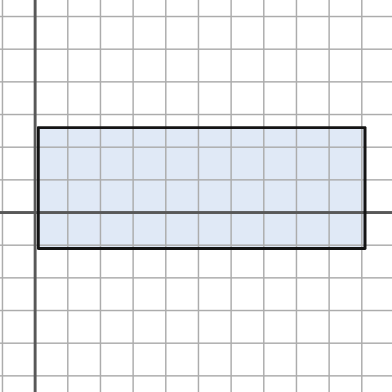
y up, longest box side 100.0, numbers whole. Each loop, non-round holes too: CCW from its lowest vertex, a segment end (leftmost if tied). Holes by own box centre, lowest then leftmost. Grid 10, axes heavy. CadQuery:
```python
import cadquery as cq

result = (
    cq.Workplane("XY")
    .moveTo(1.0, -11.0)
    .lineTo(101.0, -11.0)
    .lineTo(101.0, 26.0)
    .lineTo(1.0, 26.0)
    .close()
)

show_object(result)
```